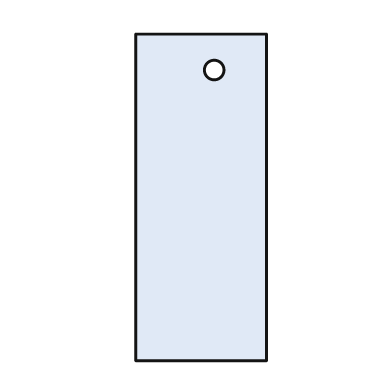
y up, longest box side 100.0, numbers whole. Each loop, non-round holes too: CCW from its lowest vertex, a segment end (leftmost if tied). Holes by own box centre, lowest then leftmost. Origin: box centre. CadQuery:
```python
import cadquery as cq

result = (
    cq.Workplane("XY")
    .moveTo(-20.0, -50.0)
    .lineTo(20.0, -50.0)
    .lineTo(20.0, 50.0)
    .lineTo(-20.0, 50.0)
    .close()
    .moveTo(4.0, 39.0)
    .circle(3.0)
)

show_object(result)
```